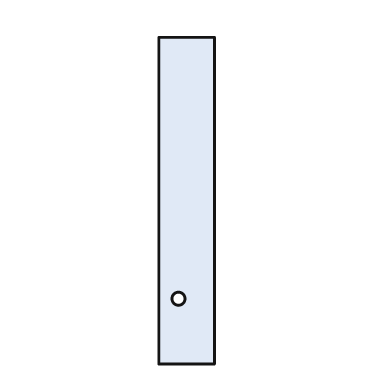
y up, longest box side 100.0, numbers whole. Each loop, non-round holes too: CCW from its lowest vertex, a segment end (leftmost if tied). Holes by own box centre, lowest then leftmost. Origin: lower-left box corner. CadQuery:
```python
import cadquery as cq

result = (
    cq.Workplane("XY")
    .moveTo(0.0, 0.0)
    .lineTo(17.0, 0.0)
    .lineTo(17.0, 100.0)
    .lineTo(0.0, 100.0)
    .close()
    .moveTo(6.0, 20.0)
    .circle(2.0)
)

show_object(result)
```